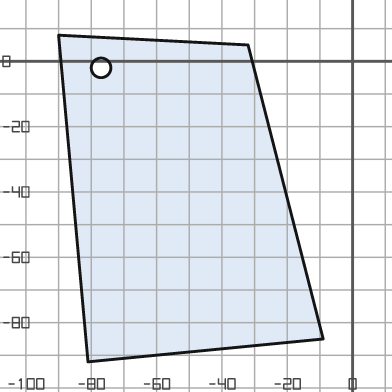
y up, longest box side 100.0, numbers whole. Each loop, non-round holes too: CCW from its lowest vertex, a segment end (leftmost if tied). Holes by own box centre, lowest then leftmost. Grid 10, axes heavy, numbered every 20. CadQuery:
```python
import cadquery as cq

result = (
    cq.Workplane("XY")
    .moveTo(-81.0, -92.0)
    .lineTo(-9.0, -85.0)
    .lineTo(-32.0, 5.0)
    .lineTo(-90.0, 8.0)
    .close()
    .moveTo(-77.0, -2.0)
    .circle(3.0)
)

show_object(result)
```